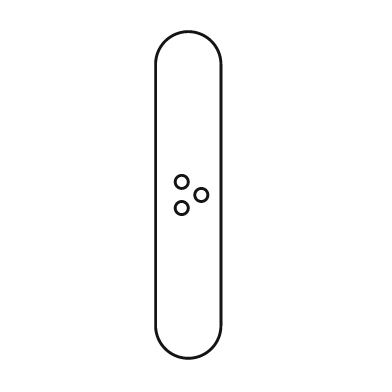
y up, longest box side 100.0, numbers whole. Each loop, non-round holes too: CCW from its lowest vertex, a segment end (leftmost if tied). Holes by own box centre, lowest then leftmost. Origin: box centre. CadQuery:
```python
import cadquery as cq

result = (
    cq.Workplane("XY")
    .moveTo(-10.0, -40.0)
    .threePointArc((0.0, -50.0), (10.0, -40.0))
    .lineTo(10.0, 40.0)
    .threePointArc((0.0, 50.0), (-10.0, 40.0))
    .close()
    .moveTo(-2.0, -4.0)
    .circle(2.0)
    .moveTo(4.0, 0.0)
    .circle(2.0)
    .moveTo(-2.0, 4.0)
    .circle(2.0)
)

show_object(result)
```